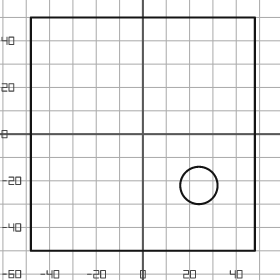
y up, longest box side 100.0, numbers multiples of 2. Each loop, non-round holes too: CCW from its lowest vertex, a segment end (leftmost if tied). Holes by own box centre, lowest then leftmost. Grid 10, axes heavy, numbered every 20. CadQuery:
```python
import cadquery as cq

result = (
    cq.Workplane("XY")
    .moveTo(-48.0, -50.0)
    .lineTo(48.0, -50.0)
    .lineTo(48.0, 50.0)
    .lineTo(-48.0, 50.0)
    .close()
    .moveTo(24.0, -22.0)
    .circle(8.0)
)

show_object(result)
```